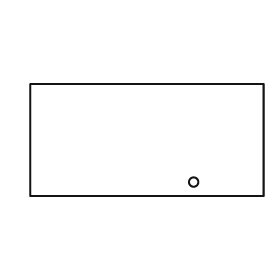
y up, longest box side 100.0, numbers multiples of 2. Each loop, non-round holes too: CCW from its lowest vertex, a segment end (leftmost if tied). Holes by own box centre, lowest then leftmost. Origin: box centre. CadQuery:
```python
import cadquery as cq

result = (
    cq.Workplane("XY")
    .moveTo(-50.0, -24.0)
    .lineTo(50.0, -24.0)
    .lineTo(50.0, 24.0)
    .lineTo(-50.0, 24.0)
    .close()
    .moveTo(20.0, -18.0)
    .circle(2.0)
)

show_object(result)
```